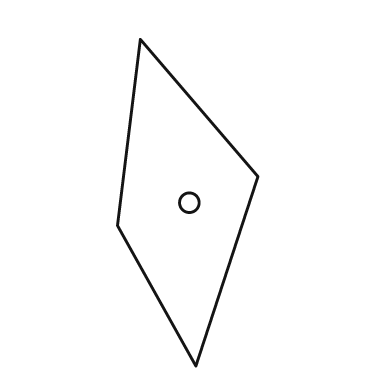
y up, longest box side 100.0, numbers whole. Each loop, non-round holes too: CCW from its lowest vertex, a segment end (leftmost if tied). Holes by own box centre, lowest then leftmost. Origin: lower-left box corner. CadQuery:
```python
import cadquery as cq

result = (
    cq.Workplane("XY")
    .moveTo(24.0, 0.0)
    .lineTo(43.0, 58.0)
    .lineTo(7.0, 100.0)
    .lineTo(0.0, 43.0)
    .close()
    .moveTo(22.0, 50.0)
    .circle(3.0)
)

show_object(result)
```